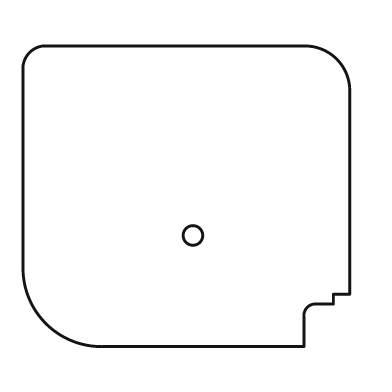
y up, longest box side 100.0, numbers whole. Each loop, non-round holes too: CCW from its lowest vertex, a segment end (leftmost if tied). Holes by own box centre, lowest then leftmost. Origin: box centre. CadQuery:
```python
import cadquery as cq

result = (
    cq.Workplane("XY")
    .moveTo(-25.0, -46.0)
    .lineTo(36.0, -46.0)
    .lineTo(36.0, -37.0)
    .threePointArc((37.0, -34.0), (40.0, -33.0))
    .lineTo(45.0, -33.0)
    .lineTo(45.0, -30.0)
    .lineTo(50.0, -30.0)
    .lineTo(50.0, 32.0)
    .threePointArc((46.0, 42.0), (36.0, 46.0))
    .lineTo(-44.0, 46.0)
    .threePointArc((-48.0, 44.0), (-50.0, 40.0))
    .lineTo(-50.0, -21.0)
    .threePointArc((-43.0, -39.0), (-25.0, -46.0))
    .close()
    .moveTo(2.0, -12.0)
    .circle(3.0)
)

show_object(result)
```